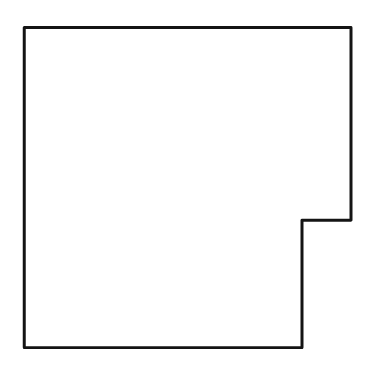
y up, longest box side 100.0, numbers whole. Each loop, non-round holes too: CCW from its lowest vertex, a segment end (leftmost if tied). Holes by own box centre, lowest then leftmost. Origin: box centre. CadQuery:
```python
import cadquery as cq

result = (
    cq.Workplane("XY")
    .moveTo(-50.0, -49.0)
    .lineTo(35.0, -49.0)
    .lineTo(35.0, -10.0)
    .lineTo(50.0, -10.0)
    .lineTo(50.0, 49.0)
    .lineTo(-50.0, 49.0)
    .close()
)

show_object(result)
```